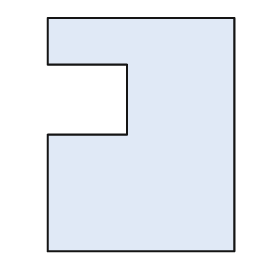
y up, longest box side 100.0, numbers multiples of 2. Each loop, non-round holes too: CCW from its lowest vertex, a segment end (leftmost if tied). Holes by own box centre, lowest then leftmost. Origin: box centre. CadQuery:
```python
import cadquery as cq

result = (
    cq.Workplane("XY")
    .moveTo(-40.0, -50.0)
    .lineTo(40.0, -50.0)
    .lineTo(40.0, 50.0)
    .lineTo(-40.0, 50.0)
    .lineTo(-40.0, 30.0)
    .lineTo(-6.0, 30.0)
    .lineTo(-6.0, 0.0)
    .lineTo(-40.0, 0.0)
    .close()
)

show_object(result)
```